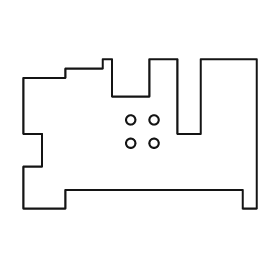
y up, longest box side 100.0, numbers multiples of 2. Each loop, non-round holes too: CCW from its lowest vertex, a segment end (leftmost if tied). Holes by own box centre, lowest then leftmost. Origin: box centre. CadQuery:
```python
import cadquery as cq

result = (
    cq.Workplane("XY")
    .moveTo(-50.0, -32.0)
    .lineTo(-32.0, -32.0)
    .lineTo(-32.0, -24.0)
    .lineTo(44.0, -24.0)
    .lineTo(44.0, -32.0)
    .lineTo(50.0, -32.0)
    .lineTo(50.0, 32.0)
    .lineTo(26.0, 32.0)
    .lineTo(26.0, 0.0)
    .lineTo(16.0, 0.0)
    .lineTo(16.0, 32.0)
    .lineTo(4.0, 32.0)
    .lineTo(4.0, 16.0)
    .lineTo(-12.0, 16.0)
    .lineTo(-12.0, 32.0)
    .lineTo(-16.0, 32.0)
    .lineTo(-16.0, 28.0)
    .lineTo(-32.0, 28.0)
    .lineTo(-32.0, 24.0)
    .lineTo(-50.0, 24.0)
    .lineTo(-50.0, 0.0)
    .lineTo(-42.0, 0.0)
    .lineTo(-42.0, -14.0)
    .lineTo(-50.0, -14.0)
    .close()
    .moveTo(-4.0, -4.0)
    .circle(2.0)
    .moveTo(6.0, -4.0)
    .circle(2.0)
    .moveTo(-4.0, 6.0)
    .circle(2.0)
    .moveTo(6.0, 6.0)
    .circle(2.0)
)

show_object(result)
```